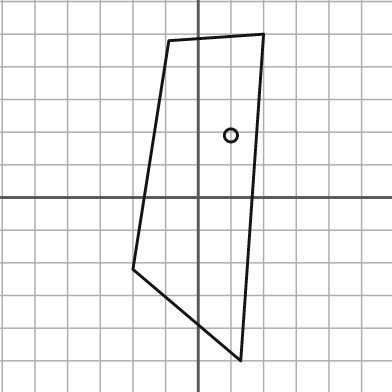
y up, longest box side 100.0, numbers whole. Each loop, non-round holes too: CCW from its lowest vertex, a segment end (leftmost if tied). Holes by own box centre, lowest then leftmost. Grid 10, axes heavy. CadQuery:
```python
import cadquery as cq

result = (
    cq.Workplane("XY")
    .moveTo(13.0, -50.0)
    .lineTo(20.0, 50.0)
    .lineTo(-9.0, 48.0)
    .lineTo(-20.0, -22.0)
    .close()
    .moveTo(10.0, 19.0)
    .circle(2.0)
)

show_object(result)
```